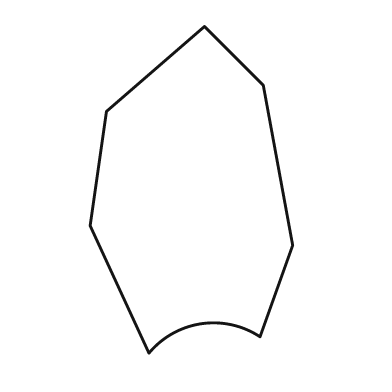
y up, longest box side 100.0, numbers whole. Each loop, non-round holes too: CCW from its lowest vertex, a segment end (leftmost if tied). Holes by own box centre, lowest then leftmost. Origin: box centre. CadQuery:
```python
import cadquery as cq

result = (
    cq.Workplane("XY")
    .moveTo(-13.0, -50.0)
    .threePointArc((3.0, -41.0), (21.0, -45.0))
    .lineTo(31.0, -17.0)
    .lineTo(22.0, 32.0)
    .lineTo(4.0, 50.0)
    .lineTo(-26.0, 24.0)
    .lineTo(-31.0, -11.0)
    .close()
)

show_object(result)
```